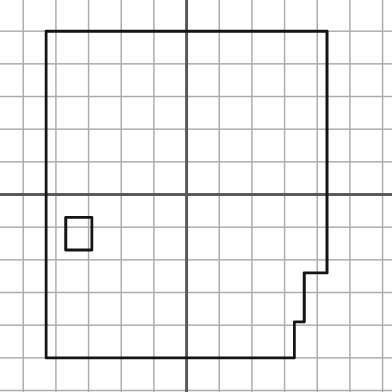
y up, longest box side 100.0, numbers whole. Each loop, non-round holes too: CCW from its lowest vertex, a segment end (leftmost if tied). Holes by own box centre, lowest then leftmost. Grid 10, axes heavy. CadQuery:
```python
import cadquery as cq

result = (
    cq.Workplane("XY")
    .moveTo(-43.0, -50.0)
    .lineTo(33.0, -50.0)
    .lineTo(33.0, -39.0)
    .lineTo(36.0, -39.0)
    .lineTo(36.0, -24.0)
    .lineTo(43.0, -24.0)
    .lineTo(43.0, 50.0)
    .lineTo(-43.0, 50.0)
    .close()
    .moveTo(-37.0, -17.0)
    .lineTo(-29.0, -17.0)
    .lineTo(-29.0, -7.0)
    .lineTo(-37.0, -7.0)
    .close()
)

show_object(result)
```